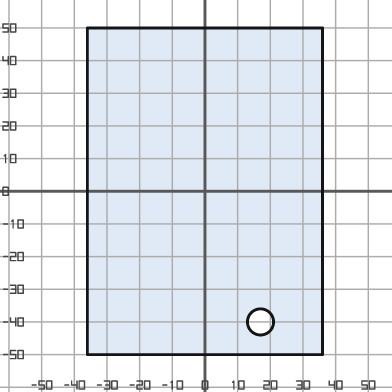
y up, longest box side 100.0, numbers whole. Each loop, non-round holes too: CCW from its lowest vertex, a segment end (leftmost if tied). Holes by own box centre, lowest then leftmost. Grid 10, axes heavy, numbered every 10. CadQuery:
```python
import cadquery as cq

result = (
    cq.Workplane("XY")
    .moveTo(-36.0, -50.0)
    .lineTo(36.0, -50.0)
    .lineTo(36.0, 50.0)
    .lineTo(-36.0, 50.0)
    .close()
    .moveTo(17.0, -40.0)
    .circle(4.0)
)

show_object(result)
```